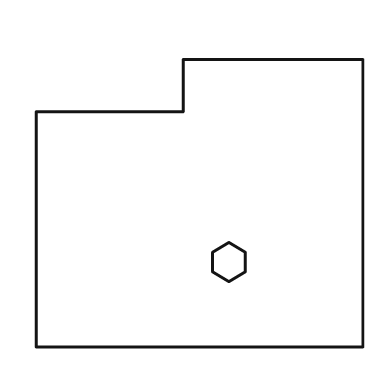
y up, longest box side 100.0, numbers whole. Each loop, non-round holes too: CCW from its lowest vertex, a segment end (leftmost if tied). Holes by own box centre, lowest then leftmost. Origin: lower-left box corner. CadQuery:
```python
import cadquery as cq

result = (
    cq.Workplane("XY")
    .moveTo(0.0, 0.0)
    .lineTo(100.0, 0.0)
    .lineTo(100.0, 88.0)
    .lineTo(45.0, 88.0)
    .lineTo(45.0, 72.0)
    .lineTo(0.0, 72.0)
    .close()
    .moveTo(59.0, 20.0)
    .lineTo(64.0, 23.0)
    .lineTo(64.0, 29.0)
    .lineTo(59.0, 32.0)
    .lineTo(54.0, 29.0)
    .lineTo(54.0, 23.0)
    .close()
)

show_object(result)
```